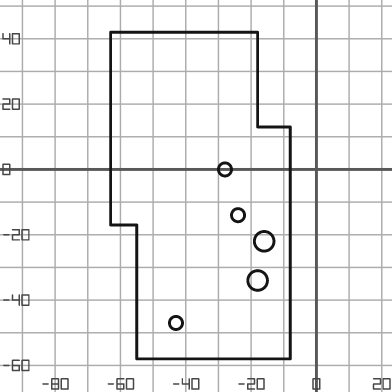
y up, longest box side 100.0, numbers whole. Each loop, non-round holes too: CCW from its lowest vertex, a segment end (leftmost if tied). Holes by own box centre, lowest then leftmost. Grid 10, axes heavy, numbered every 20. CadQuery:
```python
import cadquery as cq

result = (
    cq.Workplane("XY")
    .moveTo(-55.0, -58.0)
    .lineTo(-8.0, -58.0)
    .lineTo(-8.0, 13.0)
    .lineTo(-18.0, 13.0)
    .lineTo(-18.0, 42.0)
    .lineTo(-63.0, 42.0)
    .lineTo(-63.0, -17.0)
    .lineTo(-55.0, -17.0)
    .close()
    .moveTo(-43.0, -47.0)
    .circle(2.0)
    .moveTo(-18.0, -34.0)
    .circle(3.0)
    .moveTo(-16.0, -22.0)
    .circle(3.0)
    .moveTo(-24.0, -14.0)
    .circle(2.0)
    .moveTo(-28.0, 0.0)
    .circle(2.0)
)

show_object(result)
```